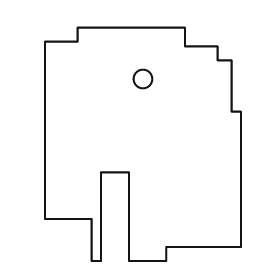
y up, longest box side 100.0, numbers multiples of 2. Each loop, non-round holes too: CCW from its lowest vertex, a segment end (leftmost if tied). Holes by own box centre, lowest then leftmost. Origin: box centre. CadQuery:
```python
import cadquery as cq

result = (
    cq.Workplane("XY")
    .moveTo(-22.0, -50.0)
    .lineTo(-18.0, -50.0)
    .lineTo(-18.0, -12.0)
    .lineTo(-6.0, -12.0)
    .lineTo(-6.0, -50.0)
    .lineTo(10.0, -50.0)
    .lineTo(10.0, -44.0)
    .lineTo(42.0, -44.0)
    .lineTo(42.0, 14.0)
    .lineTo(38.0, 14.0)
    .lineTo(38.0, 36.0)
    .lineTo(32.0, 36.0)
    .lineTo(32.0, 42.0)
    .lineTo(18.0, 42.0)
    .lineTo(18.0, 50.0)
    .lineTo(-28.0, 50.0)
    .lineTo(-28.0, 44.0)
    .lineTo(-42.0, 44.0)
    .lineTo(-42.0, -32.0)
    .lineTo(-22.0, -32.0)
    .close()
    .moveTo(0.0, 28.0)
    .circle(4.0)
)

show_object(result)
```